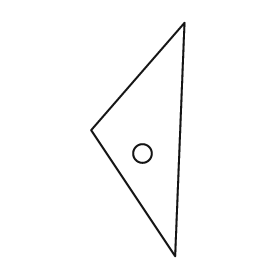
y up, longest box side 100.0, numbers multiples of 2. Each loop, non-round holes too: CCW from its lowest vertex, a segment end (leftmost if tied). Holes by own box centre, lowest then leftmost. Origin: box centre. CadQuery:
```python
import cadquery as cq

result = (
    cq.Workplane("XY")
    .moveTo(16.0, -50.0)
    .lineTo(20.0, 50.0)
    .lineTo(-20.0, 4.0)
    .close()
    .moveTo(2.0, -6.0)
    .circle(4.0)
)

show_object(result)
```